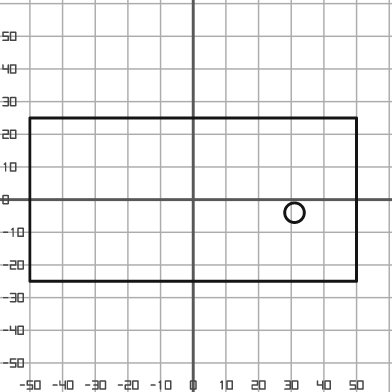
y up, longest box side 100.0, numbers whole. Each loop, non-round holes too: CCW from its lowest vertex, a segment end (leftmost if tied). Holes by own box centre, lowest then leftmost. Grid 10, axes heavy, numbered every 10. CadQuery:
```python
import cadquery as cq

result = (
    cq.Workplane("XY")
    .moveTo(-50.0, -25.0)
    .lineTo(50.0, -25.0)
    .lineTo(50.0, 25.0)
    .lineTo(-50.0, 25.0)
    .close()
    .moveTo(31.0, -4.0)
    .circle(3.0)
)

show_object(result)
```